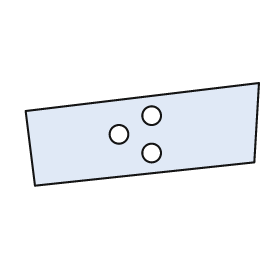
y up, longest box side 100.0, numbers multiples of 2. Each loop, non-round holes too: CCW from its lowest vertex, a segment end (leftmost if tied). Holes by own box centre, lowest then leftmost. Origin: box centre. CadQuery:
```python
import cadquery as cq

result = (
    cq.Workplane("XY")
    .moveTo(-46.0, -22.0)
    .lineTo(48.0, -12.0)
    .lineTo(50.0, 22.0)
    .lineTo(-50.0, 10.0)
    .close()
    .moveTo(4.0, -8.0)
    .circle(4.0)
    .moveTo(-10.0, 0.0)
    .circle(4.0)
    .moveTo(4.0, 8.0)
    .circle(4.0)
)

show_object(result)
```